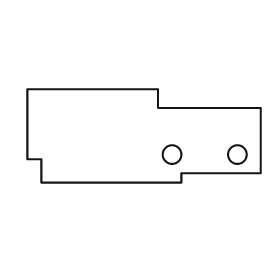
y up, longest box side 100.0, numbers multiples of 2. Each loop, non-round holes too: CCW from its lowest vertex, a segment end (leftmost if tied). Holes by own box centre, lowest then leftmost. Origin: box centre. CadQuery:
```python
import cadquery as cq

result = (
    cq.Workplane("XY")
    .moveTo(-44.0, -20.0)
    .lineTo(16.0, -20.0)
    .lineTo(16.0, -16.0)
    .lineTo(50.0, -16.0)
    .lineTo(50.0, 12.0)
    .lineTo(6.0, 12.0)
    .lineTo(6.0, 20.0)
    .lineTo(-50.0, 20.0)
    .lineTo(-50.0, -10.0)
    .lineTo(-44.0, -10.0)
    .close()
    .moveTo(12.0, -8.0)
    .circle(4.0)
    .moveTo(40.0, -8.0)
    .circle(4.0)
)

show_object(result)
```